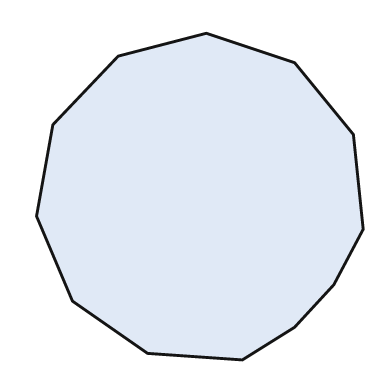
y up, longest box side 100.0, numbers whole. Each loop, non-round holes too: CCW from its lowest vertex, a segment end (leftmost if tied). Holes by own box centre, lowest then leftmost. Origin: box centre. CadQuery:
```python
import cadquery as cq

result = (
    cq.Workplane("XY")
    .moveTo(13.0, -50.0)
    .lineTo(29.0, -40.0)
    .lineTo(41.0, -27.0)
    .lineTo(50.0, -10.0)
    .lineTo(47.0, 19.0)
    .lineTo(29.0, 41.0)
    .lineTo(2.0, 50.0)
    .lineTo(-25.0, 43.0)
    .lineTo(-45.0, 22.0)
    .lineTo(-50.0, -6.0)
    .lineTo(-39.0, -32.0)
    .lineTo(-16.0, -48.0)
    .close()
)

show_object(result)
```